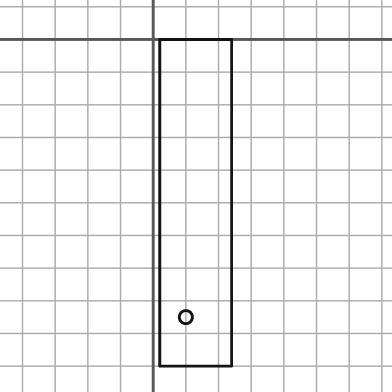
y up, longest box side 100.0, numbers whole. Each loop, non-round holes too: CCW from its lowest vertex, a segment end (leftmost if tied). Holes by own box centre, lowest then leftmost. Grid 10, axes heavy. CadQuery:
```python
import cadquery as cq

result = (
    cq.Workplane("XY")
    .moveTo(2.0, -100.0)
    .lineTo(24.0, -100.0)
    .lineTo(24.0, 0.0)
    .lineTo(2.0, 0.0)
    .close()
    .moveTo(10.0, -85.0)
    .circle(2.0)
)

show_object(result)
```